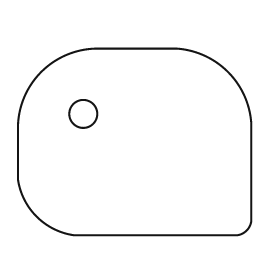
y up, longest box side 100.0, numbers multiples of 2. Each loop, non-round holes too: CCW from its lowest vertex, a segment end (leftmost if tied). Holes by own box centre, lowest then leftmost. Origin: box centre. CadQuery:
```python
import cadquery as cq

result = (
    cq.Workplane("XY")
    .moveTo(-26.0, -40.0)
    .lineTo(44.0, -40.0)
    .threePointArc((48.0, -38.0), (50.0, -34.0))
    .lineTo(50.0, 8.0)
    .threePointArc((40.0, 30.0), (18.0, 40.0))
    .lineTo(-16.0, 40.0)
    .threePointArc((-40.0, 30.0), (-50.0, 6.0))
    .lineTo(-50.0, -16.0)
    .threePointArc((-42.0, -32.0), (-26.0, -40.0))
    .close()
    .moveTo(-22.0, 12.0)
    .circle(6.0)
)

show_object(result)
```